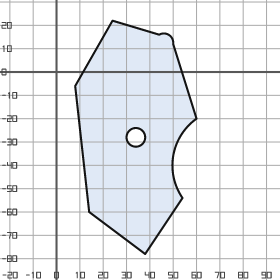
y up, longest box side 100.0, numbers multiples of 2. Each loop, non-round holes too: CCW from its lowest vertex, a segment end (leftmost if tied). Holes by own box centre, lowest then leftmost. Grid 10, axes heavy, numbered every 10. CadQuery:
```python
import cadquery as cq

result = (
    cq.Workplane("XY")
    .moveTo(38.0, -78.0)
    .lineTo(54.0, -54.0)
    .threePointArc((50.0, -36.0), (60.0, -20.0))
    .lineTo(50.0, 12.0)
    .threePointArc((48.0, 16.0), (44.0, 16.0))
    .lineTo(24.0, 22.0)
    .lineTo(8.0, -6.0)
    .lineTo(14.0, -60.0)
    .close()
    .moveTo(34.0, -28.0)
    .circle(4.0)
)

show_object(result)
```